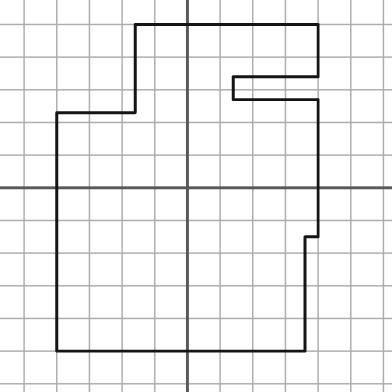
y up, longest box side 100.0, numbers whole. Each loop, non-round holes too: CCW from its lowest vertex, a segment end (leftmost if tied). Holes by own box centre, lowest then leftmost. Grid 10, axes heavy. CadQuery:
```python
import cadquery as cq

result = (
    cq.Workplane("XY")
    .moveTo(-40.0, -50.0)
    .lineTo(36.0, -50.0)
    .lineTo(36.0, -15.0)
    .lineTo(40.0, -15.0)
    .lineTo(40.0, 27.0)
    .lineTo(14.0, 27.0)
    .lineTo(14.0, 34.0)
    .lineTo(40.0, 34.0)
    .lineTo(40.0, 50.0)
    .lineTo(-16.0, 50.0)
    .lineTo(-16.0, 23.0)
    .lineTo(-40.0, 23.0)
    .close()
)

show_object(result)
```